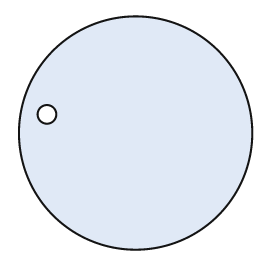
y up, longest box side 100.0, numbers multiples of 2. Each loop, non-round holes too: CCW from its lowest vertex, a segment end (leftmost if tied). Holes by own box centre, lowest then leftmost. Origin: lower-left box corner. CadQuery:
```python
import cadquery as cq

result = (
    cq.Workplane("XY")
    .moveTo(50.0, 50.0)
    .circle(50.0)
    .moveTo(12.0, 58.0)
    .circle(4.0)
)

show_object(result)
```